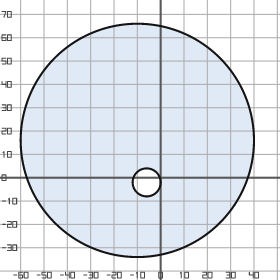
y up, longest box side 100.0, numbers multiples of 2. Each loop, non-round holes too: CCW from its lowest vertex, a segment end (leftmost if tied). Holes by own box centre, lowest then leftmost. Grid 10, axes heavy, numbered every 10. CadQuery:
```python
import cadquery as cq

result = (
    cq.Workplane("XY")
    .moveTo(-10.0, 16.0)
    .circle(50.0)
    .moveTo(-6.0, -2.0)
    .circle(6.0)
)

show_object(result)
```